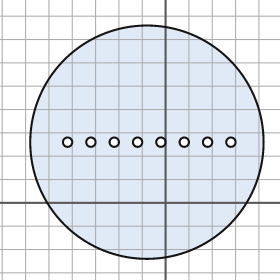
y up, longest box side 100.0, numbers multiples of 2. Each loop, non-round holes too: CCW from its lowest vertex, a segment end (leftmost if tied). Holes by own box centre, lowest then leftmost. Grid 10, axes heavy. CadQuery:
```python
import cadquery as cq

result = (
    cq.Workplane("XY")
    .moveTo(-8.0, 26.0)
    .circle(50.0)
    .moveTo(-42.0, 26.0)
    .circle(2.0)
    .moveTo(-32.0, 26.0)
    .circle(2.0)
    .moveTo(-22.0, 26.0)
    .circle(2.0)
    .moveTo(-12.0, 26.0)
    .circle(2.0)
    .moveTo(-2.0, 26.0)
    .circle(2.0)
    .moveTo(8.0, 26.0)
    .circle(2.0)
    .moveTo(18.0, 26.0)
    .circle(2.0)
    .moveTo(28.0, 26.0)
    .circle(2.0)
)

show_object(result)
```